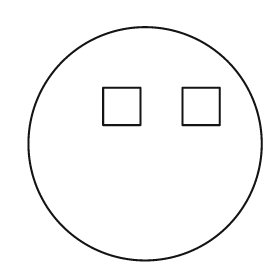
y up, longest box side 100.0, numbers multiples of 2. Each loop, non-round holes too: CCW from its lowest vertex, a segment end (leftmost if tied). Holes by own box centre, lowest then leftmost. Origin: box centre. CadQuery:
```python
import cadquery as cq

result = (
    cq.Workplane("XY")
    .moveTo(0.0, 0.0)
    .circle(50.0)
    .moveTo(-18.0, 8.0)
    .lineTo(-2.0, 8.0)
    .lineTo(-2.0, 24.0)
    .lineTo(-18.0, 24.0)
    .close()
    .moveTo(16.0, 8.0)
    .lineTo(32.0, 8.0)
    .lineTo(32.0, 24.0)
    .lineTo(16.0, 24.0)
    .close()
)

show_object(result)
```